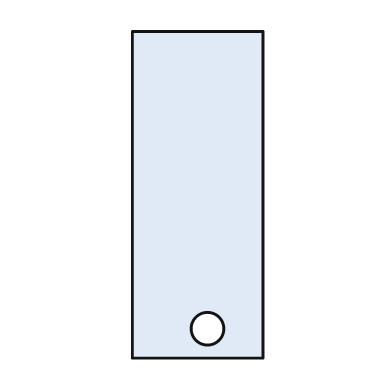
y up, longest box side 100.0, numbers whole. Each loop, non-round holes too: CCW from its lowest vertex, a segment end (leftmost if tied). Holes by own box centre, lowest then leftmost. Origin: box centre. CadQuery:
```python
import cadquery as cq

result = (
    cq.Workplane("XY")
    .moveTo(-20.0, -50.0)
    .lineTo(20.0, -50.0)
    .lineTo(20.0, 50.0)
    .lineTo(-20.0, 50.0)
    .close()
    .moveTo(3.0, -41.0)
    .circle(5.0)
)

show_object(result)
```